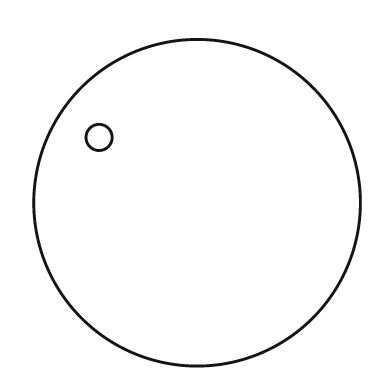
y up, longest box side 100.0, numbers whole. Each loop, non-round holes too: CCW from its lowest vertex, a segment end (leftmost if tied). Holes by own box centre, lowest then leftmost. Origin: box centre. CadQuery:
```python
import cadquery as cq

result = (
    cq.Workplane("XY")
    .moveTo(0.0, 0.0)
    .circle(50.0)
    .moveTo(-30.0, 20.0)
    .circle(4.0)
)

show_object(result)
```